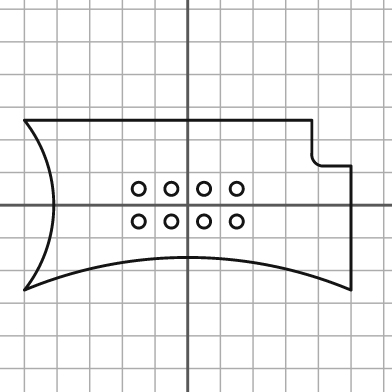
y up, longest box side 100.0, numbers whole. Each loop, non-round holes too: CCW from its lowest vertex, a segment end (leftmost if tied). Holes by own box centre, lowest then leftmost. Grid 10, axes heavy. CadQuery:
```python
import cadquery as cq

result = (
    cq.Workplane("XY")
    .moveTo(-50.0, -26.0)
    .threePointArc((0.0, -16.0), (50.0, -26.0))
    .lineTo(50.0, 12.0)
    .lineTo(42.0, 12.0)
    .threePointArc((39.0, 13.0), (38.0, 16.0))
    .lineTo(38.0, 26.0)
    .lineTo(-50.0, 26.0)
    .threePointArc((-41.0, 0.0), (-50.0, -26.0))
    .close()
    .moveTo(-15.0, -5.0)
    .circle(2.0)
    .moveTo(-5.0, -5.0)
    .circle(2.0)
    .moveTo(5.0, -5.0)
    .circle(2.0)
    .moveTo(15.0, -5.0)
    .circle(2.0)
    .moveTo(-15.0, 5.0)
    .circle(2.0)
    .moveTo(-5.0, 5.0)
    .circle(2.0)
    .moveTo(5.0, 5.0)
    .circle(2.0)
    .moveTo(15.0, 5.0)
    .circle(2.0)
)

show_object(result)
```